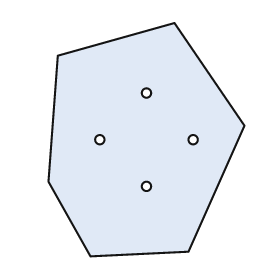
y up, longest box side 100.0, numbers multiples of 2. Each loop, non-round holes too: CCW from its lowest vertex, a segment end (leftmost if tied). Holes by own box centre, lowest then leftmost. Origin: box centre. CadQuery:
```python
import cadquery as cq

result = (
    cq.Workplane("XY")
    .moveTo(-24.0, -50.0)
    .lineTo(18.0, -48.0)
    .lineTo(42.0, 6.0)
    .lineTo(12.0, 50.0)
    .lineTo(-38.0, 36.0)
    .lineTo(-42.0, -18.0)
    .close()
    .moveTo(0.0, -20.0)
    .circle(2.0)
    .moveTo(-20.0, 0.0)
    .circle(2.0)
    .moveTo(20.0, 0.0)
    .circle(2.0)
    .moveTo(0.0, 20.0)
    .circle(2.0)
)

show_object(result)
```